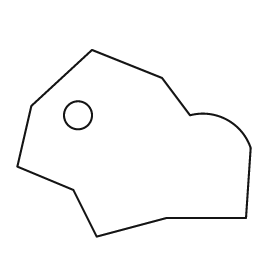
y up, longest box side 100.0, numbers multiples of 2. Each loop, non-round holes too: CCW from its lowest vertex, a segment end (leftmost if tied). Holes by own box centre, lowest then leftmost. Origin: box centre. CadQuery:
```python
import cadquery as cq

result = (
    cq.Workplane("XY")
    .moveTo(-16.0, -40.0)
    .lineTo(14.0, -32.0)
    .lineTo(48.0, -32.0)
    .lineTo(50.0, -2.0)
    .threePointArc((40.0, 10.0), (24.0, 12.0))
    .lineTo(12.0, 28.0)
    .lineTo(-18.0, 40.0)
    .lineTo(-44.0, 16.0)
    .lineTo(-50.0, -10.0)
    .lineTo(-26.0, -20.0)
    .close()
    .moveTo(-24.0, 12.0)
    .circle(6.0)
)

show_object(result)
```